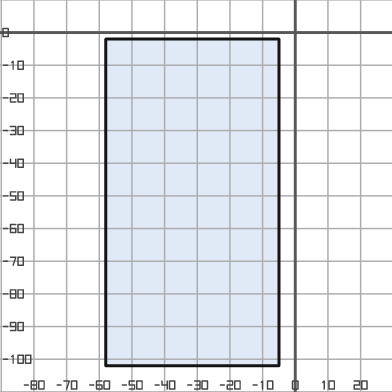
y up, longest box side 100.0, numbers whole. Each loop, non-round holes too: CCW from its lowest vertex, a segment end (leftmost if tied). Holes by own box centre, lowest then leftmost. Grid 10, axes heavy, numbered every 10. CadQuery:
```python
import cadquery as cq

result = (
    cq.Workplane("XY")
    .moveTo(-58.0, -102.0)
    .lineTo(-5.0, -102.0)
    .lineTo(-5.0, -2.0)
    .lineTo(-58.0, -2.0)
    .close()
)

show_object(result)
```